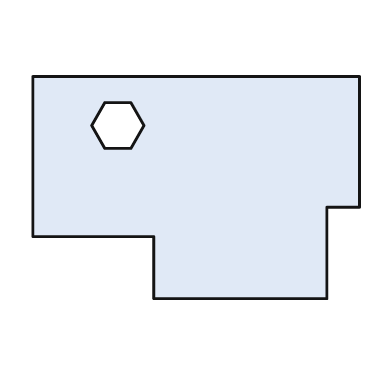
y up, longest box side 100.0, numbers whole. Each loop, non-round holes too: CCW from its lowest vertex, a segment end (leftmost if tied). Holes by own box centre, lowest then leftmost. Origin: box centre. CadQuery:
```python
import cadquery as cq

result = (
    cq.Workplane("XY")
    .moveTo(-13.0, -34.0)
    .lineTo(40.0, -34.0)
    .lineTo(40.0, -6.0)
    .lineTo(50.0, -6.0)
    .lineTo(50.0, 34.0)
    .lineTo(-50.0, 34.0)
    .lineTo(-50.0, -15.0)
    .lineTo(-13.0, -15.0)
    .close()
    .moveTo(-28.0, 12.0)
    .lineTo(-20.0, 12.0)
    .lineTo(-16.0, 19.0)
    .lineTo(-20.0, 26.0)
    .lineTo(-28.0, 26.0)
    .lineTo(-32.0, 19.0)
    .close()
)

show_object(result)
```